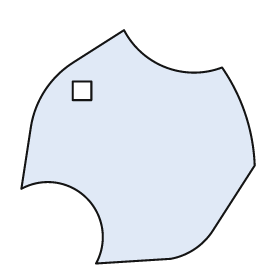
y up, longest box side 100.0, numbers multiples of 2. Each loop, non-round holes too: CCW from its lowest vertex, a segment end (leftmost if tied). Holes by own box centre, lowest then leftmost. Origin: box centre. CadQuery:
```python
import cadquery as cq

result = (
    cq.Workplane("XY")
    .moveTo(-18.0, -50.0)
    .lineTo(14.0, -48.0)
    .threePointArc((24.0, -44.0), (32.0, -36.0))
    .lineTo(50.0, -8.0)
    .threePointArc((46.0, 14.0), (36.0, 34.0))
    .threePointArc((12.0, 34.0), (-6.0, 50.0))
    .lineTo(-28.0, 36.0)
    .threePointArc((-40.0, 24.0), (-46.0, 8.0))
    .lineTo(-50.0, -18.0)
    .threePointArc((-22.0, -22.0), (-18.0, -50.0))
    .close()
    .moveTo(-28.0, 20.0)
    .lineTo(-20.0, 20.0)
    .lineTo(-20.0, 28.0)
    .lineTo(-28.0, 28.0)
    .close()
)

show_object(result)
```